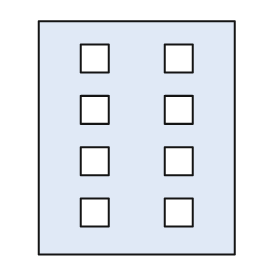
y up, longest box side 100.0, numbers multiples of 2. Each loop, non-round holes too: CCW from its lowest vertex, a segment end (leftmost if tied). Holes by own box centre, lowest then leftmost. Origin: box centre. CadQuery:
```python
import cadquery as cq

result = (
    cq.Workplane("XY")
    .moveTo(-42.0, -50.0)
    .lineTo(42.0, -50.0)
    .lineTo(42.0, 50.0)
    .lineTo(-42.0, 50.0)
    .close()
    .moveTo(-24.0, -38.0)
    .lineTo(-12.0, -38.0)
    .lineTo(-12.0, -26.0)
    .lineTo(-24.0, -26.0)
    .close()
    .moveTo(12.0, -38.0)
    .lineTo(24.0, -38.0)
    .lineTo(24.0, -26.0)
    .lineTo(12.0, -26.0)
    .close()
    .moveTo(-24.0, -16.0)
    .lineTo(-12.0, -16.0)
    .lineTo(-12.0, -4.0)
    .lineTo(-24.0, -4.0)
    .close()
    .moveTo(12.0, -16.0)
    .lineTo(24.0, -16.0)
    .lineTo(24.0, -4.0)
    .lineTo(12.0, -4.0)
    .close()
    .moveTo(-24.0, 6.0)
    .lineTo(-12.0, 6.0)
    .lineTo(-12.0, 18.0)
    .lineTo(-24.0, 18.0)
    .close()
    .moveTo(12.0, 6.0)
    .lineTo(24.0, 6.0)
    .lineTo(24.0, 18.0)
    .lineTo(12.0, 18.0)
    .close()
    .moveTo(-24.0, 28.0)
    .lineTo(-12.0, 28.0)
    .lineTo(-12.0, 40.0)
    .lineTo(-24.0, 40.0)
    .close()
    .moveTo(12.0, 28.0)
    .lineTo(24.0, 28.0)
    .lineTo(24.0, 40.0)
    .lineTo(12.0, 40.0)
    .close()
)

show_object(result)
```